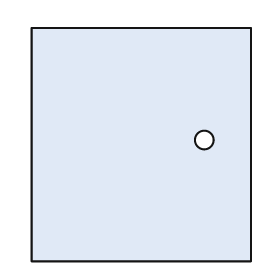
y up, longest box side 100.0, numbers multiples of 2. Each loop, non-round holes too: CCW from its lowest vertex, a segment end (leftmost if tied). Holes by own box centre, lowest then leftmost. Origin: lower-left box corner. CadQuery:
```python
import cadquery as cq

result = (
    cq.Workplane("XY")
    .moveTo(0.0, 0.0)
    .lineTo(94.0, 0.0)
    .lineTo(94.0, 100.0)
    .lineTo(0.0, 100.0)
    .close()
    .moveTo(74.0, 52.0)
    .circle(4.0)
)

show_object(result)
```